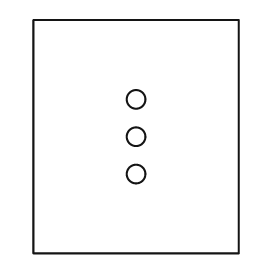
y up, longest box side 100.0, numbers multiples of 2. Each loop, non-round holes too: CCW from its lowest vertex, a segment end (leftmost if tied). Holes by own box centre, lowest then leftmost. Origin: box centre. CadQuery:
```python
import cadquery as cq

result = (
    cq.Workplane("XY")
    .moveTo(-44.0, -50.0)
    .lineTo(44.0, -50.0)
    .lineTo(44.0, 50.0)
    .lineTo(-44.0, 50.0)
    .close()
    .moveTo(0.0, -16.0)
    .circle(4.0)
    .moveTo(0.0, 0.0)
    .circle(4.0)
    .moveTo(0.0, 16.0)
    .circle(4.0)
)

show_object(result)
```